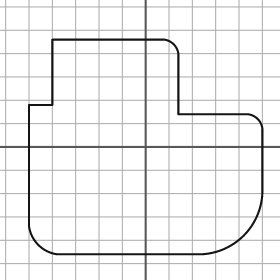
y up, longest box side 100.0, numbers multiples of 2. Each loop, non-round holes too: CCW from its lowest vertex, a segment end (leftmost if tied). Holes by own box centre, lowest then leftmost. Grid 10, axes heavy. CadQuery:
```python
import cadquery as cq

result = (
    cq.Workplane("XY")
    .moveTo(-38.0, -46.0)
    .lineTo(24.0, -46.0)
    .threePointArc((42.0, -38.0), (50.0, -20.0))
    .lineTo(50.0, 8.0)
    .threePointArc((48.0, 12.0), (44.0, 14.0))
    .lineTo(14.0, 14.0)
    .lineTo(14.0, 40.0)
    .threePointArc((12.0, 44.0), (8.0, 46.0))
    .lineTo(-40.0, 46.0)
    .lineTo(-40.0, 18.0)
    .lineTo(-50.0, 18.0)
    .lineTo(-50.0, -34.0)
    .threePointArc((-46.0, -42.0), (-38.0, -46.0))
    .close()
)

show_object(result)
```